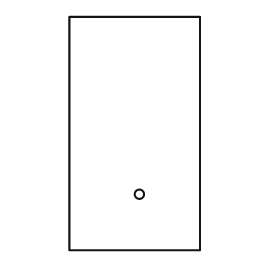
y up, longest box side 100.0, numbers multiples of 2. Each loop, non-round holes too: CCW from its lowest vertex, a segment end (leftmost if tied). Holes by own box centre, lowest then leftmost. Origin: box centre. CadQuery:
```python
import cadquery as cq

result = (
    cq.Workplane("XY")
    .moveTo(-28.0, -50.0)
    .lineTo(28.0, -50.0)
    .lineTo(28.0, 50.0)
    .lineTo(-28.0, 50.0)
    .close()
    .moveTo(2.0, -26.0)
    .circle(2.0)
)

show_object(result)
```